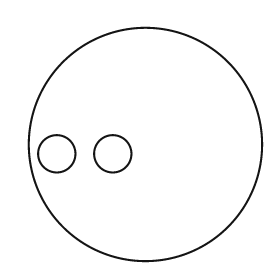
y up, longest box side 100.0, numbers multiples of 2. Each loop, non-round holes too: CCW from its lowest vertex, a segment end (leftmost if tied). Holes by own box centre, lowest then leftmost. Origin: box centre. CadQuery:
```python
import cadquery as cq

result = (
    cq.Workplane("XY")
    .moveTo(0.0, 0.0)
    .circle(50.0)
    .moveTo(-38.0, -4.0)
    .circle(8.0)
    .moveTo(-14.0, -4.0)
    .circle(8.0)
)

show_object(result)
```